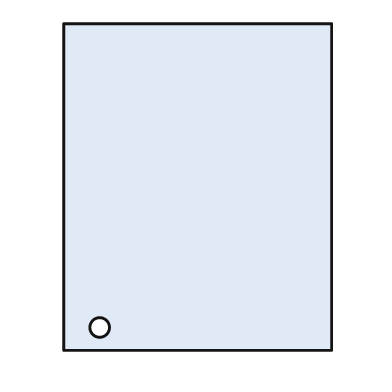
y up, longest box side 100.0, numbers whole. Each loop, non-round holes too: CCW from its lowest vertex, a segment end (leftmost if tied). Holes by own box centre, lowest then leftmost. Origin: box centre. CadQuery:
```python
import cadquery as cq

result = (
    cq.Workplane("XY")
    .moveTo(-41.0, -50.0)
    .lineTo(41.0, -50.0)
    .lineTo(41.0, 50.0)
    .lineTo(-41.0, 50.0)
    .close()
    .moveTo(-30.0, -43.0)
    .circle(3.0)
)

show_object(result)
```